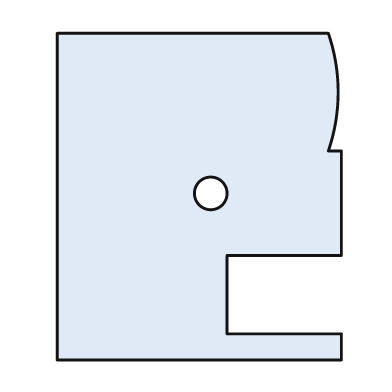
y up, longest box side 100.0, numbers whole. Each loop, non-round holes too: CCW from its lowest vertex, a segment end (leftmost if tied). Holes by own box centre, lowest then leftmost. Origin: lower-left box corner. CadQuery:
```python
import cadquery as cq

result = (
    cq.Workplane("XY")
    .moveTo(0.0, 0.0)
    .lineTo(87.0, 0.0)
    .lineTo(87.0, 8.0)
    .lineTo(52.0, 8.0)
    .lineTo(52.0, 32.0)
    .lineTo(87.0, 32.0)
    .lineTo(87.0, 64.0)
    .lineTo(83.0, 64.0)
    .threePointArc((86.0, 82.0), (83.0, 100.0))
    .lineTo(0.0, 100.0)
    .close()
    .moveTo(47.0, 51.0)
    .circle(5.0)
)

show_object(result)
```